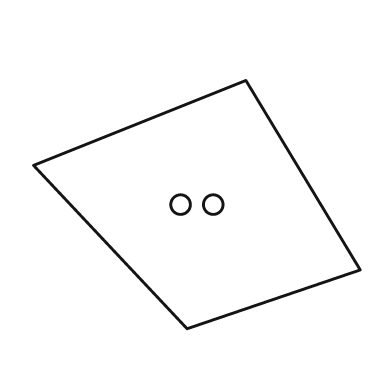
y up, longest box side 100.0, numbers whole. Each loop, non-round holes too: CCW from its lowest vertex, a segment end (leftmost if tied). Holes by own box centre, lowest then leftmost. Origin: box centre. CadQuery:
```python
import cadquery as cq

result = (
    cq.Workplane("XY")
    .moveTo(-3.0, -38.0)
    .lineTo(50.0, -20.0)
    .lineTo(15.0, 38.0)
    .lineTo(-50.0, 12.0)
    .close()
    .moveTo(-5.0, 0.0)
    .circle(3.0)
    .moveTo(5.0, 0.0)
    .circle(3.0)
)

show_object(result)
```